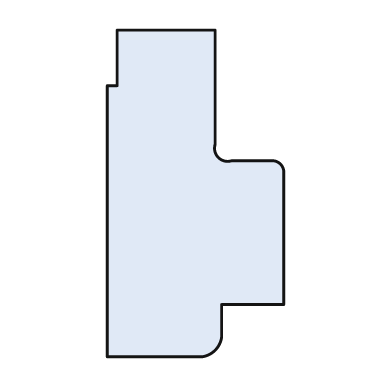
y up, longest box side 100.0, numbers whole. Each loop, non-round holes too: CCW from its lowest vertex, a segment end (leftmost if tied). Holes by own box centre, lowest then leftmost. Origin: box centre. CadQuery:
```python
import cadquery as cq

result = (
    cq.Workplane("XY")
    .moveTo(-27.0, -50.0)
    .lineTo(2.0, -50.0)
    .threePointArc((6.0, -48.0), (8.0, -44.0))
    .lineTo(8.0, -34.0)
    .lineTo(27.0, -34.0)
    .lineTo(27.0, 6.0)
    .threePointArc((26.0, 9.0), (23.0, 10.0))
    .lineTo(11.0, 10.0)
    .threePointArc((7.0, 11.0), (6.0, 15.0))
    .lineTo(6.0, 50.0)
    .lineTo(-24.0, 50.0)
    .lineTo(-24.0, 33.0)
    .lineTo(-27.0, 33.0)
    .close()
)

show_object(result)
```